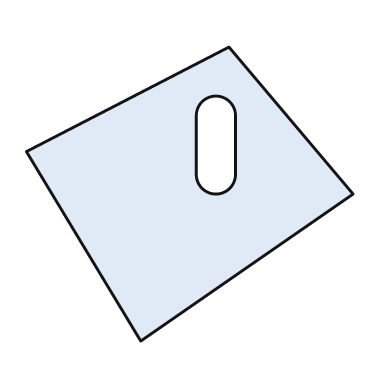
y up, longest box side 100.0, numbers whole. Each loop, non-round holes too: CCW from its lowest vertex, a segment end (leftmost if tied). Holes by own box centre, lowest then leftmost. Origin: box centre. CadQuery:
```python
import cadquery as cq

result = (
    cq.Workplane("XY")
    .moveTo(-15.0, -45.0)
    .lineTo(50.0, 0.0)
    .lineTo(12.0, 45.0)
    .lineTo(-50.0, 13.0)
    .close()
    .moveTo(2.0, 6.0)
    .threePointArc((8.0, 0.0), (14.0, 6.0))
    .lineTo(14.0, 24.0)
    .threePointArc((8.0, 30.0), (2.0, 24.0))
    .close()
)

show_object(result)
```